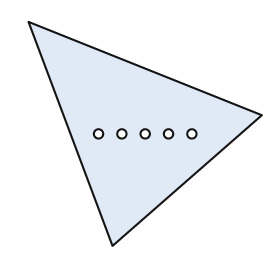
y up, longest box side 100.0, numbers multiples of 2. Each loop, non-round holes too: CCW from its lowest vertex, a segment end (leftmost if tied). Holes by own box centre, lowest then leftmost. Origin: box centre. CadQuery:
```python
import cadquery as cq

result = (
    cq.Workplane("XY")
    .moveTo(-14.0, -48.0)
    .lineTo(50.0, 8.0)
    .lineTo(-50.0, 48.0)
    .close()
    .moveTo(-20.0, 0.0)
    .circle(2.0)
    .moveTo(-10.0, 0.0)
    .circle(2.0)
    .moveTo(0.0, 0.0)
    .circle(2.0)
    .moveTo(10.0, 0.0)
    .circle(2.0)
    .moveTo(20.0, 0.0)
    .circle(2.0)
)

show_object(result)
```